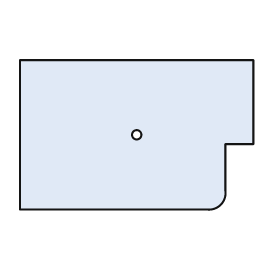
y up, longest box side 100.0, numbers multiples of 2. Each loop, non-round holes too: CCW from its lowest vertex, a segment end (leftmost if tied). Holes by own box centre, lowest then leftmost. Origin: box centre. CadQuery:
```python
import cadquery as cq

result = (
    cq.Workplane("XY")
    .moveTo(-50.0, -32.0)
    .lineTo(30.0, -32.0)
    .threePointArc((36.0, -30.0), (38.0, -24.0))
    .lineTo(38.0, -4.0)
    .lineTo(50.0, -4.0)
    .lineTo(50.0, 32.0)
    .lineTo(-50.0, 32.0)
    .close()
    .moveTo(0.0, 0.0)
    .circle(2.0)
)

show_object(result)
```